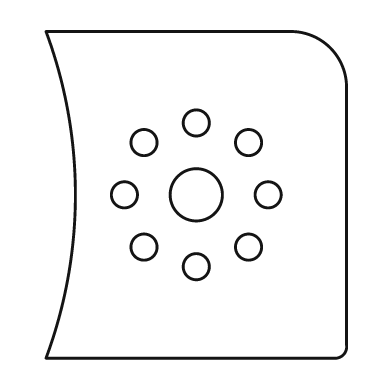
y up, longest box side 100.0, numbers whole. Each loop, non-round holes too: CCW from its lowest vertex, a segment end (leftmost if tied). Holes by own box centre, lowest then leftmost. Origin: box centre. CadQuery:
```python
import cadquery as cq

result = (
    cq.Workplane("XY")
    .moveTo(-46.0, -50.0)
    .lineTo(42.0, -50.0)
    .threePointArc((45.0, -49.0), (46.0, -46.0))
    .lineTo(46.0, 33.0)
    .threePointArc((41.0, 45.0), (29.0, 50.0))
    .lineTo(-46.0, 50.0)
    .threePointArc((-37.0, 0.0), (-46.0, -50.0))
    .close()
    .moveTo(0.0, -22.0)
    .circle(4.0)
    .moveTo(-16.0, -16.0)
    .circle(4.0)
    .moveTo(16.0, -16.0)
    .circle(4.0)
    .moveTo(-22.0, 0.0)
    .circle(4.0)
    .moveTo(0.0, 0.0)
    .circle(8.0)
    .moveTo(22.0, 0.0)
    .circle(4.0)
    .moveTo(-16.0, 16.0)
    .circle(4.0)
    .moveTo(16.0, 16.0)
    .circle(4.0)
    .moveTo(0.0, 22.0)
    .circle(4.0)
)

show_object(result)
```